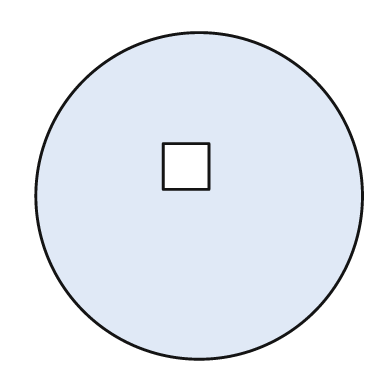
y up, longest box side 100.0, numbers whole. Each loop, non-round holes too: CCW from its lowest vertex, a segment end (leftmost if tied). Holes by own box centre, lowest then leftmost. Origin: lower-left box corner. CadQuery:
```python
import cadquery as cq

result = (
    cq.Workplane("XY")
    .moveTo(50.0, 50.0)
    .circle(50.0)
    .moveTo(39.0, 52.0)
    .lineTo(53.0, 52.0)
    .lineTo(53.0, 66.0)
    .lineTo(39.0, 66.0)
    .close()
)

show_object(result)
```